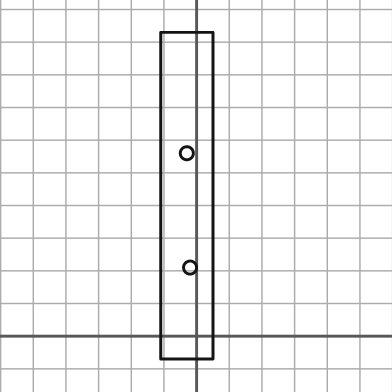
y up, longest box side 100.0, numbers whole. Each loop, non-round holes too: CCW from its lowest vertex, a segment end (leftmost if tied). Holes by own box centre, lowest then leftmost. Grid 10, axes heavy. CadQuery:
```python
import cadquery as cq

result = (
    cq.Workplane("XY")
    .moveTo(-11.0, -7.0)
    .lineTo(5.0, -7.0)
    .lineTo(5.0, 93.0)
    .lineTo(-11.0, 93.0)
    .close()
    .moveTo(-2.0, 21.0)
    .circle(2.0)
    .moveTo(-3.0, 56.0)
    .circle(2.0)
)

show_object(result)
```